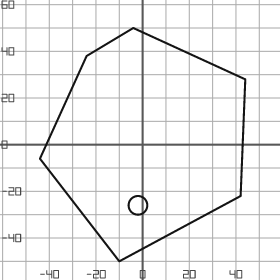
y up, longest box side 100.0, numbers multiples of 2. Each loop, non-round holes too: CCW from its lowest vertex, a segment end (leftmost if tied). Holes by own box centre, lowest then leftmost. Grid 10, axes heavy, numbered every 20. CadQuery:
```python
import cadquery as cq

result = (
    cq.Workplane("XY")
    .moveTo(-10.0, -50.0)
    .lineTo(42.0, -22.0)
    .lineTo(44.0, 28.0)
    .lineTo(-4.0, 50.0)
    .lineTo(-24.0, 38.0)
    .lineTo(-44.0, -6.0)
    .close()
    .moveTo(-2.0, -26.0)
    .circle(4.0)
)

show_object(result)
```